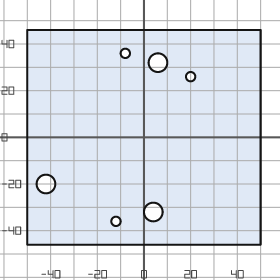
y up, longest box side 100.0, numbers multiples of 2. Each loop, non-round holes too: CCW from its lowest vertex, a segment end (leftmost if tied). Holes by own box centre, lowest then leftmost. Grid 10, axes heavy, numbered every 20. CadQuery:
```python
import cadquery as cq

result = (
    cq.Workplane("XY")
    .moveTo(-50.0, -46.0)
    .lineTo(50.0, -46.0)
    .lineTo(50.0, 46.0)
    .lineTo(-50.0, 46.0)
    .close()
    .moveTo(-12.0, -36.0)
    .circle(2.0)
    .moveTo(4.0, -32.0)
    .circle(4.0)
    .moveTo(-42.0, -20.0)
    .circle(4.0)
    .moveTo(20.0, 26.0)
    .circle(2.0)
    .moveTo(6.0, 32.0)
    .circle(4.0)
    .moveTo(-8.0, 36.0)
    .circle(2.0)
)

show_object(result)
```